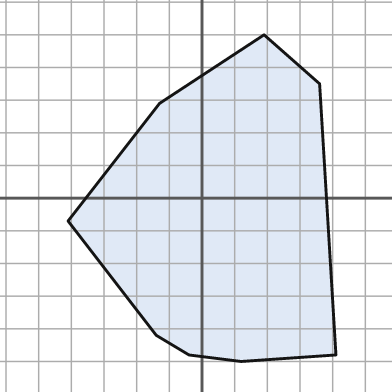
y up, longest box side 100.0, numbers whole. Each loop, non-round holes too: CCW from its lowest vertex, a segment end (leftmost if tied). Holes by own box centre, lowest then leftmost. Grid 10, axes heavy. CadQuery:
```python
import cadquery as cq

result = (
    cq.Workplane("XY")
    .moveTo(12.0, -50.0)
    .lineTo(41.0, -48.0)
    .lineTo(36.0, 35.0)
    .lineTo(19.0, 50.0)
    .lineTo(-13.0, 29.0)
    .lineTo(-41.0, -7.0)
    .lineTo(-14.0, -42.0)
    .lineTo(-4.0, -48.0)
    .close()
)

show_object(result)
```